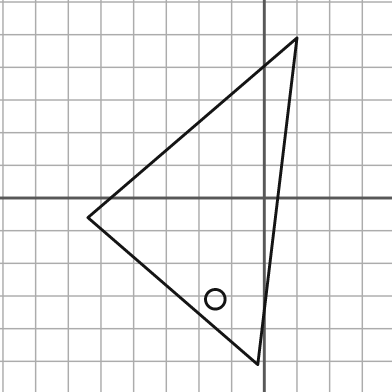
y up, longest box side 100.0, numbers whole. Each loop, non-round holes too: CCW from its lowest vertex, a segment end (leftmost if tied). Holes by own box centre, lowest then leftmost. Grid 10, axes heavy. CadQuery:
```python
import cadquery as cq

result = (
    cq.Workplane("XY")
    .moveTo(-2.0, -51.0)
    .lineTo(10.0, 49.0)
    .lineTo(-54.0, -6.0)
    .close()
    .moveTo(-15.0, -31.0)
    .circle(3.0)
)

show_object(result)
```